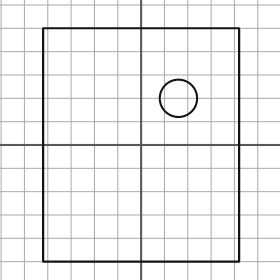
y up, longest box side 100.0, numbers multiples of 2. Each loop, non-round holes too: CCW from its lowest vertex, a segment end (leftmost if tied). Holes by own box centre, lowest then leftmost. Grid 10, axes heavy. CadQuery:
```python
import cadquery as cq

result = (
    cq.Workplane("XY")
    .moveTo(-42.0, -50.0)
    .lineTo(42.0, -50.0)
    .lineTo(42.0, 50.0)
    .lineTo(-42.0, 50.0)
    .close()
    .moveTo(16.0, 20.0)
    .circle(8.0)
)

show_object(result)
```